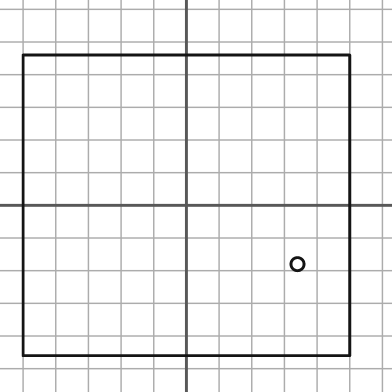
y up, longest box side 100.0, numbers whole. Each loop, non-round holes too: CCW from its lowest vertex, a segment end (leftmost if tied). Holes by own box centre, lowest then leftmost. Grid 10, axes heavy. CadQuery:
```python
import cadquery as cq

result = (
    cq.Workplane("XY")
    .moveTo(-50.0, -46.0)
    .lineTo(50.0, -46.0)
    .lineTo(50.0, 46.0)
    .lineTo(-50.0, 46.0)
    .close()
    .moveTo(34.0, -18.0)
    .circle(2.0)
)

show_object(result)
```